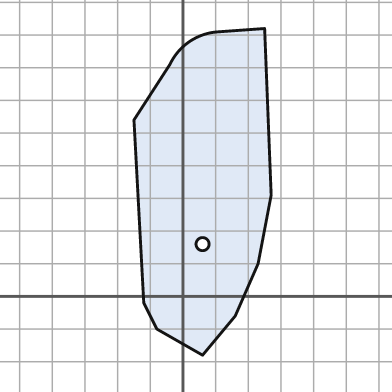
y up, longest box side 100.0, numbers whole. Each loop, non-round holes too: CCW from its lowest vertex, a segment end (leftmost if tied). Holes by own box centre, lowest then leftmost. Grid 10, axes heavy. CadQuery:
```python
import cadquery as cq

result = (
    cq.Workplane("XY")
    .moveTo(6.0, -18.0)
    .lineTo(16.0, -6.0)
    .lineTo(23.0, 10.0)
    .lineTo(27.0, 31.0)
    .lineTo(25.0, 82.0)
    .lineTo(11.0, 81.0)
    .threePointArc((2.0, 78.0), (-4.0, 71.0))
    .lineTo(-15.0, 54.0)
    .lineTo(-12.0, -2.0)
    .lineTo(-8.0, -10.0)
    .close()
    .moveTo(6.0, 16.0)
    .circle(2.0)
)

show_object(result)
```